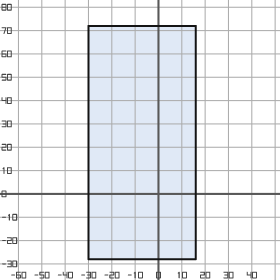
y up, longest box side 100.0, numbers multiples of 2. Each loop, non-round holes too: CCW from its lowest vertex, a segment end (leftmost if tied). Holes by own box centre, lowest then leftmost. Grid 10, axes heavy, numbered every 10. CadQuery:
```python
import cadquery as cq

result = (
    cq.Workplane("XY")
    .moveTo(-30.0, -28.0)
    .lineTo(16.0, -28.0)
    .lineTo(16.0, 72.0)
    .lineTo(-30.0, 72.0)
    .close()
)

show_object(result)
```